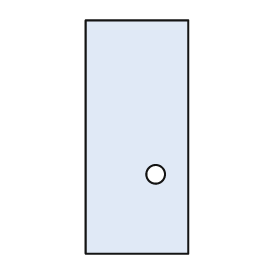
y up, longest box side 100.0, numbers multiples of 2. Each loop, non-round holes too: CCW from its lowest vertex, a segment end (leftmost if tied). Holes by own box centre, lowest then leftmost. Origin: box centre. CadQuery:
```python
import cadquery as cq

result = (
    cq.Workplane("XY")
    .moveTo(-22.0, -50.0)
    .lineTo(22.0, -50.0)
    .lineTo(22.0, 50.0)
    .lineTo(-22.0, 50.0)
    .close()
    .moveTo(8.0, -16.0)
    .circle(4.0)
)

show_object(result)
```